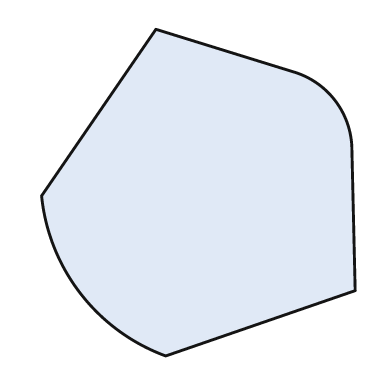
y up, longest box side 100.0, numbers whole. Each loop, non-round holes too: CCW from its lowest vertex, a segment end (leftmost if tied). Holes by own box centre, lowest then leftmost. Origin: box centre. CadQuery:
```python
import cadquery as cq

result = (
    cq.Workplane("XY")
    .moveTo(-10.0, -50.0)
    .lineTo(48.0, -30.0)
    .lineTo(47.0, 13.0)
    .threePointArc((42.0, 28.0), (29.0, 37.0))
    .lineTo(-13.0, 50.0)
    .lineTo(-48.0, -1.0)
    .threePointArc((-36.0, -31.0), (-10.0, -50.0))
    .close()
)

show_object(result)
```